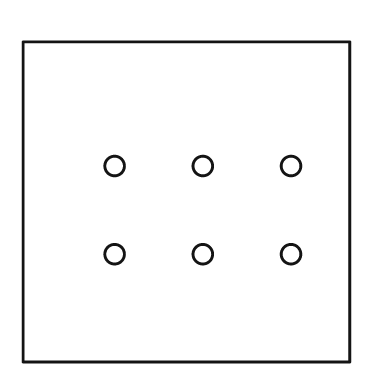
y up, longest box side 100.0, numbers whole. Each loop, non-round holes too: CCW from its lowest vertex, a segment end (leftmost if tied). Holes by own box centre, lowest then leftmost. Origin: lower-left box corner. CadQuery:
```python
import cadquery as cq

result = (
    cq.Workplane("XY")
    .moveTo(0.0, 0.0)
    .lineTo(100.0, 0.0)
    .lineTo(100.0, 98.0)
    .lineTo(0.0, 98.0)
    .close()
    .moveTo(28.0, 33.0)
    .circle(3.0)
    .moveTo(55.0, 33.0)
    .circle(3.0)
    .moveTo(82.0, 33.0)
    .circle(3.0)
    .moveTo(28.0, 60.0)
    .circle(3.0)
    .moveTo(55.0, 60.0)
    .circle(3.0)
    .moveTo(82.0, 60.0)
    .circle(3.0)
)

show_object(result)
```